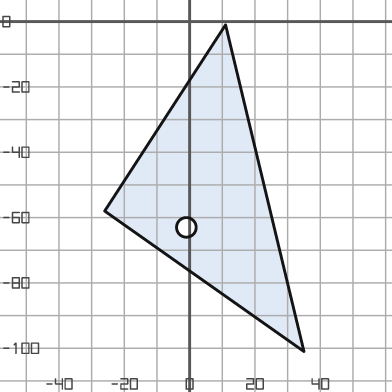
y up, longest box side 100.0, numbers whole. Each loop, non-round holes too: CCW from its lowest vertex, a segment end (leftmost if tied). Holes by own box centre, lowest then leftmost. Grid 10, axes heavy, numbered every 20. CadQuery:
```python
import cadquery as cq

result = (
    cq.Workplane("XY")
    .moveTo(35.0, -101.0)
    .lineTo(11.0, -1.0)
    .lineTo(-26.0, -58.0)
    .close()
    .moveTo(-1.0, -63.0)
    .circle(3.0)
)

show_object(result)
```